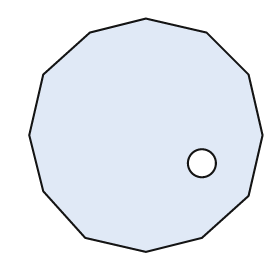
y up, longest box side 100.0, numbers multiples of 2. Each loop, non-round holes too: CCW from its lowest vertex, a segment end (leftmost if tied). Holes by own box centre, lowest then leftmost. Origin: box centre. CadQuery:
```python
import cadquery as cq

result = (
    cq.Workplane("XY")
    .moveTo(0.0, -50.0)
    .lineTo(24.0, -44.0)
    .lineTo(44.0, -26.0)
    .lineTo(50.0, 0.0)
    .lineTo(44.0, 26.0)
    .lineTo(26.0, 44.0)
    .lineTo(0.0, 50.0)
    .lineTo(-24.0, 44.0)
    .lineTo(-44.0, 26.0)
    .lineTo(-50.0, 0.0)
    .lineTo(-44.0, -24.0)
    .lineTo(-26.0, -44.0)
    .close()
    .moveTo(24.0, -12.0)
    .circle(6.0)
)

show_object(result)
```